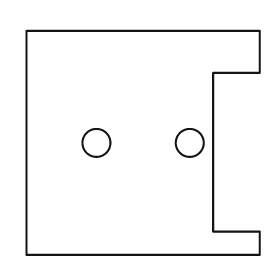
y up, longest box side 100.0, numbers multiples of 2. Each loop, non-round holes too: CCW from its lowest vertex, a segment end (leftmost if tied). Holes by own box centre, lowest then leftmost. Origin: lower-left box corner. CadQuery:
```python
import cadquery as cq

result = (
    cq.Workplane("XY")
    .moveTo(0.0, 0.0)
    .lineTo(100.0, 0.0)
    .lineTo(100.0, 10.0)
    .lineTo(80.0, 10.0)
    .lineTo(80.0, 78.0)
    .lineTo(100.0, 78.0)
    .lineTo(100.0, 96.0)
    .lineTo(0.0, 96.0)
    .close()
    .moveTo(30.0, 48.0)
    .circle(6.0)
    .moveTo(70.0, 48.0)
    .circle(6.0)
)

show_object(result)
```